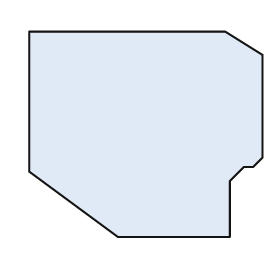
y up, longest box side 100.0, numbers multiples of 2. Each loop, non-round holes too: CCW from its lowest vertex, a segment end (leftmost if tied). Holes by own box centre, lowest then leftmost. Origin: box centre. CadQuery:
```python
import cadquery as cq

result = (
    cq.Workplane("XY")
    .moveTo(-12.0, -44.0)
    .lineTo(36.0, -44.0)
    .lineTo(36.0, -20.0)
    .lineTo(42.0, -14.0)
    .lineTo(46.0, -14.0)
    .lineTo(50.0, -10.0)
    .lineTo(50.0, 34.0)
    .lineTo(34.0, 44.0)
    .lineTo(-50.0, 44.0)
    .lineTo(-50.0, -16.0)
    .close()
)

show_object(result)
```